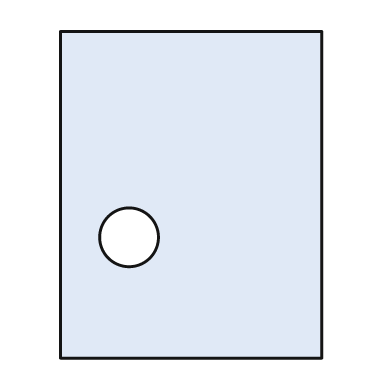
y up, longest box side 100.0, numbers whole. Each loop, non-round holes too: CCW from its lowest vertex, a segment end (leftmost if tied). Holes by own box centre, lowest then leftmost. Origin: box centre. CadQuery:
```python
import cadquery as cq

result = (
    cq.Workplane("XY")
    .moveTo(-40.0, -50.0)
    .lineTo(40.0, -50.0)
    .lineTo(40.0, 50.0)
    .lineTo(-40.0, 50.0)
    .close()
    .moveTo(-19.0, -13.0)
    .circle(9.0)
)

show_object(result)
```